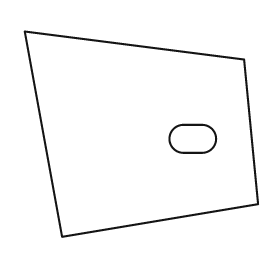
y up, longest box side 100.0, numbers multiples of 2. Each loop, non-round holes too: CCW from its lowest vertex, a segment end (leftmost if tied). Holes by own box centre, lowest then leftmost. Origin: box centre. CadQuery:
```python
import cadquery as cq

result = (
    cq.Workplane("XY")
    .moveTo(-34.0, -44.0)
    .lineTo(50.0, -30.0)
    .lineTo(44.0, 32.0)
    .lineTo(-50.0, 44.0)
    .close()
    .moveTo(18.0, -8.0)
    .lineTo(26.0, -8.0)
    .threePointArc((32.0, -2.0), (26.0, 4.0))
    .lineTo(18.0, 4.0)
    .threePointArc((12.0, -2.0), (18.0, -8.0))
    .close()
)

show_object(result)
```